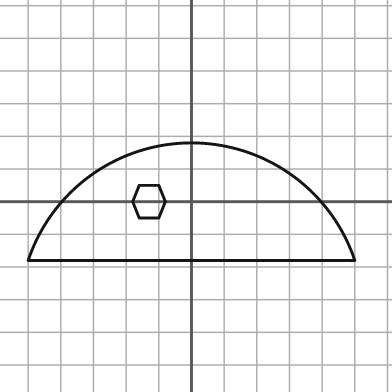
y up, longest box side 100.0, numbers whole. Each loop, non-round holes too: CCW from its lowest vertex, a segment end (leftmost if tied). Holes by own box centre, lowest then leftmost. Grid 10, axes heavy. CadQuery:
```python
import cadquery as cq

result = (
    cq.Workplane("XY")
    .moveTo(-50.0, -18.0)
    .lineTo(50.0, -18.0)
    .threePointArc((0.0, 18.0), (-50.0, -18.0))
    .close()
    .moveTo(-16.0, -5.0)
    .lineTo(-10.0, -5.0)
    .lineTo(-8.0, 0.0)
    .lineTo(-10.0, 5.0)
    .lineTo(-16.0, 5.0)
    .lineTo(-18.0, 0.0)
    .close()
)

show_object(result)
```